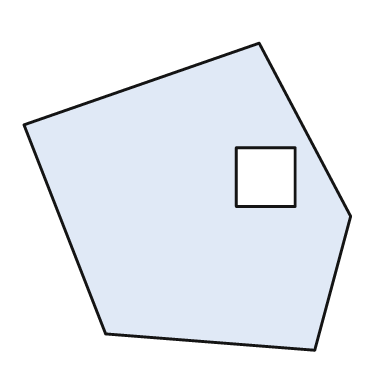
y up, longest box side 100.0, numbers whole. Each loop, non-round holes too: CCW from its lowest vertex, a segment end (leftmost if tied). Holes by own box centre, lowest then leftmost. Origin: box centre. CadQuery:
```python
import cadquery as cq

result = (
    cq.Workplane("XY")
    .moveTo(39.0, -47.0)
    .lineTo(50.0, -6.0)
    .lineTo(22.0, 47.0)
    .lineTo(-50.0, 22.0)
    .lineTo(-25.0, -42.0)
    .close()
    .moveTo(15.0, -3.0)
    .lineTo(33.0, -3.0)
    .lineTo(33.0, 15.0)
    .lineTo(15.0, 15.0)
    .close()
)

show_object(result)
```